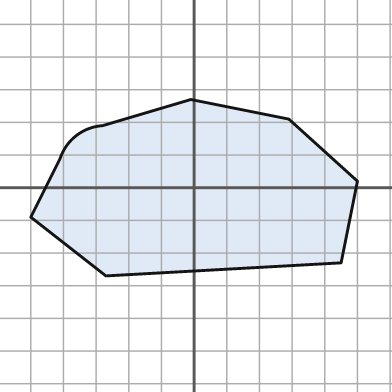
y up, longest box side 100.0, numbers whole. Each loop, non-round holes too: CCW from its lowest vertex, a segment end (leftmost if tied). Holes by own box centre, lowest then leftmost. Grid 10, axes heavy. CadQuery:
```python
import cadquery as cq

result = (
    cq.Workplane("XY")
    .moveTo(-27.0, -27.0)
    .lineTo(45.0, -23.0)
    .lineTo(50.0, 2.0)
    .lineTo(29.0, 21.0)
    .lineTo(-1.0, 27.0)
    .lineTo(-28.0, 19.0)
    .threePointArc((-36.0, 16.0), (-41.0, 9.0))
    .lineTo(-50.0, -9.0)
    .close()
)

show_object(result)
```